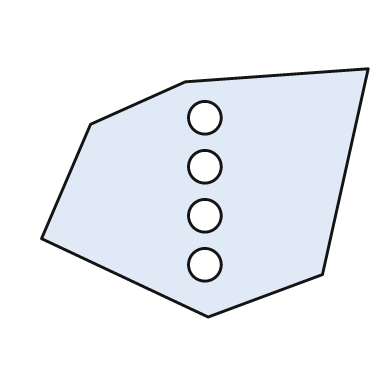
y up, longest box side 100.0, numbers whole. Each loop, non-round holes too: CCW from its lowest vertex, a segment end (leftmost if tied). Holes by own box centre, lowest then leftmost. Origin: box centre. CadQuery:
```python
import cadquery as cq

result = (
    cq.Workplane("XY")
    .moveTo(1.0, -38.0)
    .lineTo(36.0, -25.0)
    .lineTo(50.0, 38.0)
    .lineTo(-6.0, 34.0)
    .lineTo(-35.0, 21.0)
    .lineTo(-50.0, -14.0)
    .close()
    .moveTo(0.0, -22.0)
    .circle(5.0)
    .moveTo(0.0, -7.0)
    .circle(5.0)
    .moveTo(0.0, 8.0)
    .circle(5.0)
    .moveTo(0.0, 23.0)
    .circle(5.0)
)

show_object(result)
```